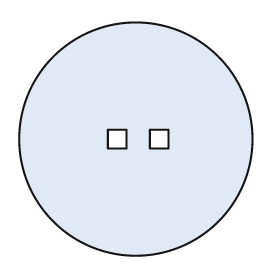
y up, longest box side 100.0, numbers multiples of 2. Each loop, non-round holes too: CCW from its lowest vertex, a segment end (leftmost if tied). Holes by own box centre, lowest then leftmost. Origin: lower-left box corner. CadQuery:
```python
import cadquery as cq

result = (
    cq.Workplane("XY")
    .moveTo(50.0, 50.0)
    .circle(50.0)
    .moveTo(38.0, 46.0)
    .lineTo(46.0, 46.0)
    .lineTo(46.0, 54.0)
    .lineTo(38.0, 54.0)
    .close()
    .moveTo(56.0, 46.0)
    .lineTo(64.0, 46.0)
    .lineTo(64.0, 54.0)
    .lineTo(56.0, 54.0)
    .close()
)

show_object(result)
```